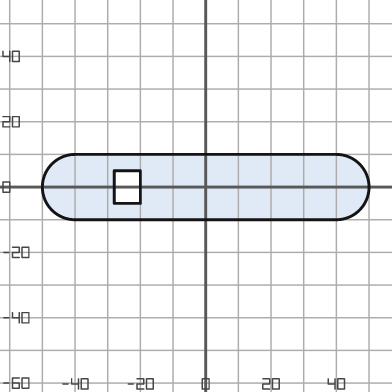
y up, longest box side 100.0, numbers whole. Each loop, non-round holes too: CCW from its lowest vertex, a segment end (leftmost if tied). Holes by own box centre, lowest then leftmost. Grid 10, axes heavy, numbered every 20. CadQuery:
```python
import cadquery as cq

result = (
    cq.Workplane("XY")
    .moveTo(-40.0, -10.0)
    .lineTo(40.0, -10.0)
    .threePointArc((50.0, 0.0), (40.0, 10.0))
    .lineTo(-40.0, 10.0)
    .threePointArc((-50.0, 0.0), (-40.0, -10.0))
    .close()
    .moveTo(-28.0, -5.0)
    .lineTo(-20.0, -5.0)
    .lineTo(-20.0, 5.0)
    .lineTo(-28.0, 5.0)
    .close()
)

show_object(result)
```